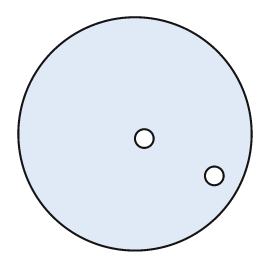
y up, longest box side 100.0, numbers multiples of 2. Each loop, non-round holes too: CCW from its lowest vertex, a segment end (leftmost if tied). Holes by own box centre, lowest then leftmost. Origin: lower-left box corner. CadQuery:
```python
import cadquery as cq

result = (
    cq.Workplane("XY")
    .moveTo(50.0, 50.0)
    .circle(50.0)
    .moveTo(84.0, 32.0)
    .circle(4.0)
    .moveTo(54.0, 48.0)
    .circle(4.0)
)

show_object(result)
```